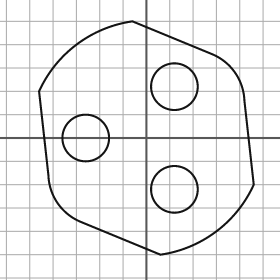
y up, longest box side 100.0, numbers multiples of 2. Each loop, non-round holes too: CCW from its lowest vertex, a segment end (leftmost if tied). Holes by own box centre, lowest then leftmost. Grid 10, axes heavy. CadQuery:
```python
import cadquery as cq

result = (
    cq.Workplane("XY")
    .moveTo(6.0, -50.0)
    .threePointArc((30.0, -40.0), (46.0, -20.0))
    .lineTo(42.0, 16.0)
    .threePointArc((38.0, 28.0), (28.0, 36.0))
    .lineTo(-6.0, 50.0)
    .threePointArc((-30.0, 40.0), (-46.0, 20.0))
    .lineTo(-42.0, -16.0)
    .threePointArc((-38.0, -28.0), (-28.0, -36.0))
    .close()
    .moveTo(12.0, -22.0)
    .circle(10.0)
    .moveTo(-26.0, 0.0)
    .circle(10.0)
    .moveTo(12.0, 22.0)
    .circle(10.0)
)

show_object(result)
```